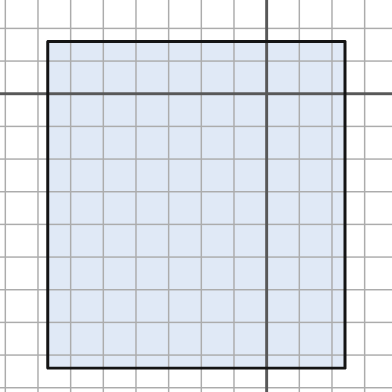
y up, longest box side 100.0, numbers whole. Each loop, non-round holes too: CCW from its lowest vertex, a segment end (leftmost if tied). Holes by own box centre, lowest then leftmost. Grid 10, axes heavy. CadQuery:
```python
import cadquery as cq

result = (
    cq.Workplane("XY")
    .moveTo(-67.0, -84.0)
    .lineTo(24.0, -84.0)
    .lineTo(24.0, 16.0)
    .lineTo(-67.0, 16.0)
    .close()
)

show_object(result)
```